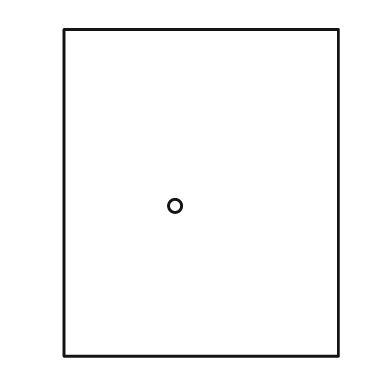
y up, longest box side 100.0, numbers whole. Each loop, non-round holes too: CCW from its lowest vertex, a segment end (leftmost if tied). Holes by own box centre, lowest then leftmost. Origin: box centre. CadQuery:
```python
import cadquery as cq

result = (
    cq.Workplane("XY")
    .moveTo(-42.0, -50.0)
    .lineTo(42.0, -50.0)
    .lineTo(42.0, 50.0)
    .lineTo(-42.0, 50.0)
    .close()
    .moveTo(-8.0, -4.0)
    .circle(2.0)
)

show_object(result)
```